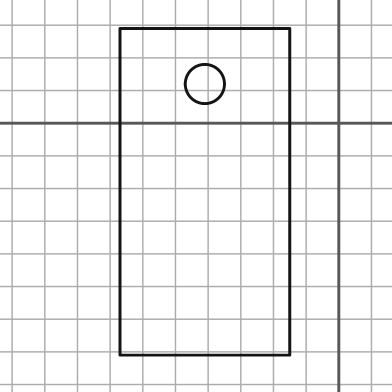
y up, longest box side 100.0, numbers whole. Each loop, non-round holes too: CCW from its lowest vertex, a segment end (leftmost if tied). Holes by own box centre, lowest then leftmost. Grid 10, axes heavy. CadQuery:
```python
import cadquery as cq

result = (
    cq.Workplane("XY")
    .moveTo(-67.0, -71.0)
    .lineTo(-15.0, -71.0)
    .lineTo(-15.0, 29.0)
    .lineTo(-67.0, 29.0)
    .close()
    .moveTo(-41.0, 12.0)
    .circle(6.0)
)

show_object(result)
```